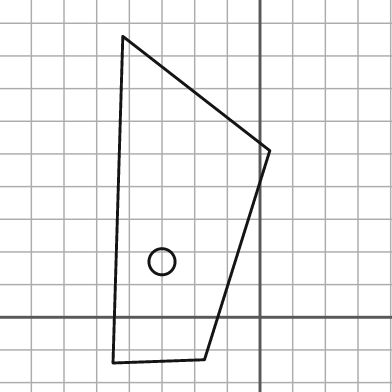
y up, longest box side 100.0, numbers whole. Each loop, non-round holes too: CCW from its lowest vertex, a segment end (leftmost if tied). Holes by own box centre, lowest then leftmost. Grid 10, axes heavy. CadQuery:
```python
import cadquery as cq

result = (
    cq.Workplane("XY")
    .moveTo(-45.0, -14.0)
    .lineTo(-17.0, -13.0)
    .lineTo(3.0, 51.0)
    .lineTo(-42.0, 86.0)
    .close()
    .moveTo(-30.0, 17.0)
    .circle(4.0)
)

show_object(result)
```